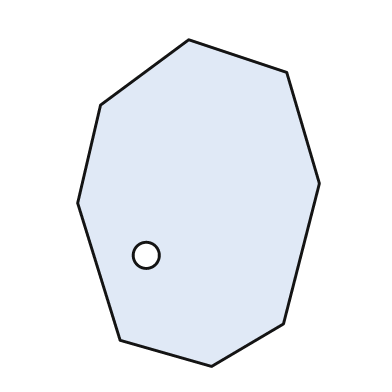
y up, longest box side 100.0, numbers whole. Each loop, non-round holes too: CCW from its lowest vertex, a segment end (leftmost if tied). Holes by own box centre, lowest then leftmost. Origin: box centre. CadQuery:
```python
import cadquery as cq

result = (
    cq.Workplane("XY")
    .moveTo(4.0, -50.0)
    .lineTo(26.0, -37.0)
    .lineTo(37.0, 6.0)
    .lineTo(27.0, 40.0)
    .lineTo(-3.0, 50.0)
    .lineTo(-30.0, 30.0)
    .lineTo(-37.0, 0.0)
    .lineTo(-24.0, -42.0)
    .close()
    .moveTo(-16.0, -16.0)
    .circle(4.0)
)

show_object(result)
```